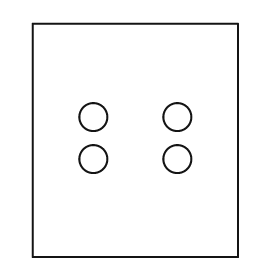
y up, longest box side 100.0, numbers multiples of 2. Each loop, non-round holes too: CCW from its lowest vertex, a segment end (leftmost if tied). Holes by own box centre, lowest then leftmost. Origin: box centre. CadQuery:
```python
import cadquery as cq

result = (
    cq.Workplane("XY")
    .moveTo(-44.0, -50.0)
    .lineTo(44.0, -50.0)
    .lineTo(44.0, 50.0)
    .lineTo(-44.0, 50.0)
    .close()
    .moveTo(-18.0, -8.0)
    .circle(6.0)
    .moveTo(18.0, -8.0)
    .circle(6.0)
    .moveTo(-18.0, 10.0)
    .circle(6.0)
    .moveTo(18.0, 10.0)
    .circle(6.0)
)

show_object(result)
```